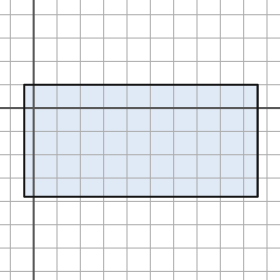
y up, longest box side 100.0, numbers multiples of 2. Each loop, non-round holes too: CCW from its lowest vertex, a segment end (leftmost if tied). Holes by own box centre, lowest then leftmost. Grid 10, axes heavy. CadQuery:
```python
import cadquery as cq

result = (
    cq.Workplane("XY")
    .moveTo(-4.0, -38.0)
    .lineTo(96.0, -38.0)
    .lineTo(96.0, 10.0)
    .lineTo(-4.0, 10.0)
    .close()
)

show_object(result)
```